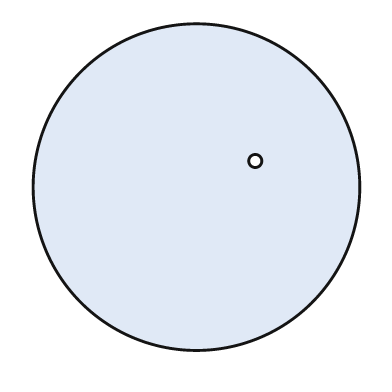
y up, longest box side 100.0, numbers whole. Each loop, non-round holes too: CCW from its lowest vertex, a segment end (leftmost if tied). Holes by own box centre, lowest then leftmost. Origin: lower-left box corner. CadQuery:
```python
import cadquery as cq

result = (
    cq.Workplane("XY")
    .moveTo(50.0, 50.0)
    .circle(50.0)
    .moveTo(68.0, 58.0)
    .circle(2.0)
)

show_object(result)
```